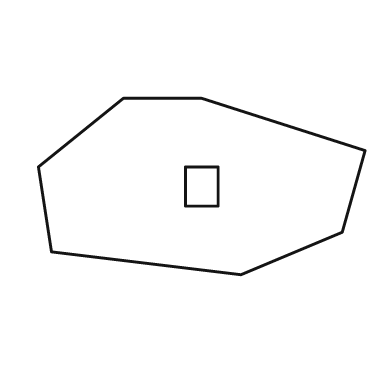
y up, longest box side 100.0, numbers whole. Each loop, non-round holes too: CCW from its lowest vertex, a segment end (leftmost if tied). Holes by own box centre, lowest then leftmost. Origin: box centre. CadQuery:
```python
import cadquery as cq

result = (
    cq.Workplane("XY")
    .moveTo(12.0, -27.0)
    .lineTo(43.0, -14.0)
    .lineTo(50.0, 11.0)
    .lineTo(0.0, 27.0)
    .lineTo(-24.0, 27.0)
    .lineTo(-50.0, 6.0)
    .lineTo(-46.0, -20.0)
    .close()
    .moveTo(-5.0, -6.0)
    .lineTo(5.0, -6.0)
    .lineTo(5.0, 6.0)
    .lineTo(-5.0, 6.0)
    .close()
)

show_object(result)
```